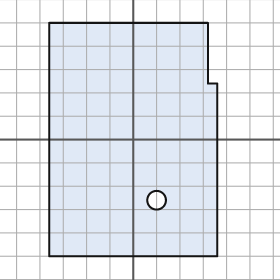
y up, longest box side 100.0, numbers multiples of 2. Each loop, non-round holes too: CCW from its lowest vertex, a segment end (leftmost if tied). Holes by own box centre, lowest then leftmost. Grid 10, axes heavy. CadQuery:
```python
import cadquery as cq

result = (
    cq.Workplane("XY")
    .moveTo(-36.0, -50.0)
    .lineTo(36.0, -50.0)
    .lineTo(36.0, 24.0)
    .lineTo(32.0, 24.0)
    .lineTo(32.0, 50.0)
    .lineTo(-36.0, 50.0)
    .close()
    .moveTo(10.0, -26.0)
    .circle(4.0)
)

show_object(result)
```